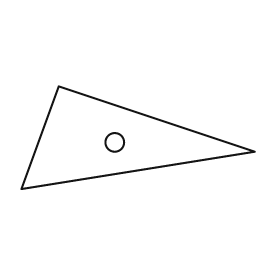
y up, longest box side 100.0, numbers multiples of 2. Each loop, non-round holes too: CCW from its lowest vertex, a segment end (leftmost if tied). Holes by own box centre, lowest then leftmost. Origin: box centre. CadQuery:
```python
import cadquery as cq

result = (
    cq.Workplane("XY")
    .moveTo(-50.0, -22.0)
    .lineTo(50.0, -6.0)
    .lineTo(-34.0, 22.0)
    .close()
    .moveTo(-10.0, -2.0)
    .circle(4.0)
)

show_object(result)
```